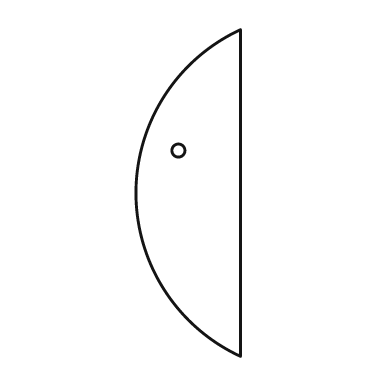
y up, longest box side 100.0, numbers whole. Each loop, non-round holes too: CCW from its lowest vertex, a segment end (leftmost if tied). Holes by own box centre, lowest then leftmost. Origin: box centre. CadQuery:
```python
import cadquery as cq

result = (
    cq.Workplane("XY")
    .moveTo(16.0, -50.0)
    .lineTo(16.0, 50.0)
    .threePointArc((-16.0, 0.0), (16.0, -50.0))
    .close()
    .moveTo(-3.0, 13.0)
    .circle(2.0)
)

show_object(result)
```